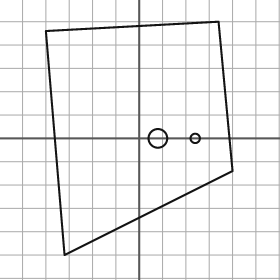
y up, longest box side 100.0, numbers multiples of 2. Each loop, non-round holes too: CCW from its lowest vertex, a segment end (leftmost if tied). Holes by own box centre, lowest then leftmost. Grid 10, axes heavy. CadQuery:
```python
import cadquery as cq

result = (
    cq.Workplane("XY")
    .moveTo(-32.0, -50.0)
    .lineTo(40.0, -14.0)
    .lineTo(34.0, 50.0)
    .lineTo(-40.0, 46.0)
    .close()
    .moveTo(8.0, 0.0)
    .circle(4.0)
    .moveTo(24.0, 0.0)
    .circle(2.0)
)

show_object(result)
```